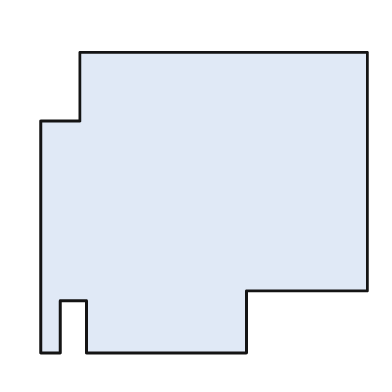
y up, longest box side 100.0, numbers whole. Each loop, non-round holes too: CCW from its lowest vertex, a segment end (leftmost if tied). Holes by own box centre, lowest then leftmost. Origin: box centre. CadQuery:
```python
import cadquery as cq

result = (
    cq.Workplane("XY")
    .moveTo(-50.0, -46.0)
    .lineTo(-44.0, -46.0)
    .lineTo(-44.0, -30.0)
    .lineTo(-36.0, -30.0)
    .lineTo(-36.0, -46.0)
    .lineTo(13.0, -46.0)
    .lineTo(13.0, -27.0)
    .lineTo(50.0, -27.0)
    .lineTo(50.0, 46.0)
    .lineTo(-38.0, 46.0)
    .lineTo(-38.0, 25.0)
    .lineTo(-50.0, 25.0)
    .close()
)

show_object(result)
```